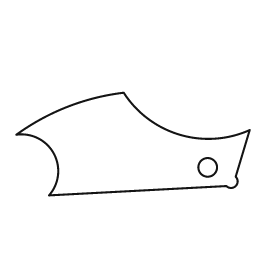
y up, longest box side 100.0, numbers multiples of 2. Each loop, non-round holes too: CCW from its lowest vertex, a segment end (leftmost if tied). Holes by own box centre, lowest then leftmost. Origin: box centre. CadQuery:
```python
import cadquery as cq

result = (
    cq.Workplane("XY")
    .moveTo(-36.0, -22.0)
    .lineTo(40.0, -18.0)
    .threePointArc((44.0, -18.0), (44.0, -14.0))
    .lineTo(50.0, 6.0)
    .threePointArc((20.0, 4.0), (-4.0, 22.0))
    .threePointArc((-28.0, 16.0), (-50.0, 4.0))
    .threePointArc((-34.0, -4.0), (-36.0, -22.0))
    .close()
    .moveTo(32.0, -10.0)
    .circle(4.0)
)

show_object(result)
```